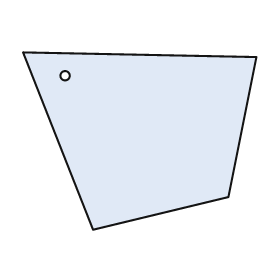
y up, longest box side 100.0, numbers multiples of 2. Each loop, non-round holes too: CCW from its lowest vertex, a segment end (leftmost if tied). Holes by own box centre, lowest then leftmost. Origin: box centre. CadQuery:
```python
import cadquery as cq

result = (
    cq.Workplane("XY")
    .moveTo(-20.0, -38.0)
    .lineTo(38.0, -24.0)
    .lineTo(50.0, 36.0)
    .lineTo(-50.0, 38.0)
    .close()
    .moveTo(-32.0, 28.0)
    .circle(2.0)
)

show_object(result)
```